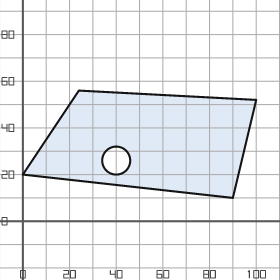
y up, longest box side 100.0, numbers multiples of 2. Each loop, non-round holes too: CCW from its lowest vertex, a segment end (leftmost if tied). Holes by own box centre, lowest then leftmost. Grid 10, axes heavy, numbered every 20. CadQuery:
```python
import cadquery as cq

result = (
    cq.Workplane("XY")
    .moveTo(90.0, 10.0)
    .lineTo(100.0, 52.0)
    .lineTo(24.0, 56.0)
    .lineTo(0.0, 20.0)
    .close()
    .moveTo(40.0, 26.0)
    .circle(6.0)
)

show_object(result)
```